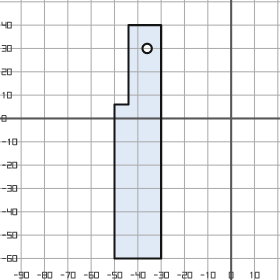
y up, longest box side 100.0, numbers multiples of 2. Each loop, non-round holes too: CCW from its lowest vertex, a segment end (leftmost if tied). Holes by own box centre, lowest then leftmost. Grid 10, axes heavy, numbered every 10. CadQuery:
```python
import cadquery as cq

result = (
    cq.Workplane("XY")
    .moveTo(-50.0, -60.0)
    .lineTo(-30.0, -60.0)
    .lineTo(-30.0, 40.0)
    .lineTo(-44.0, 40.0)
    .lineTo(-44.0, 6.0)
    .lineTo(-50.0, 6.0)
    .close()
    .moveTo(-36.0, 30.0)
    .circle(2.0)
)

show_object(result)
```